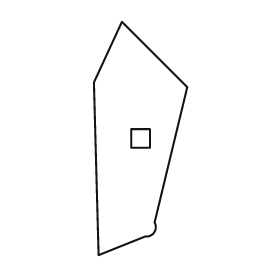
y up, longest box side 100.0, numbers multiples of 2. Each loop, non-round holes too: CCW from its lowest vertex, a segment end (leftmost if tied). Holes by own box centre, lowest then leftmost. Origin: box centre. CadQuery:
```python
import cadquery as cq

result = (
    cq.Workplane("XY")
    .moveTo(-18.0, -50.0)
    .lineTo(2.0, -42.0)
    .threePointArc((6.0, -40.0), (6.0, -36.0))
    .lineTo(20.0, 22.0)
    .lineTo(-8.0, 50.0)
    .lineTo(-20.0, 24.0)
    .close()
    .moveTo(-4.0, -4.0)
    .lineTo(4.0, -4.0)
    .lineTo(4.0, 4.0)
    .lineTo(-4.0, 4.0)
    .close()
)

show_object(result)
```